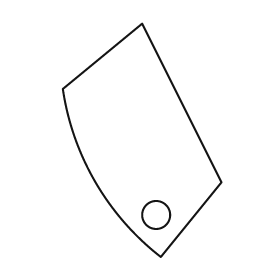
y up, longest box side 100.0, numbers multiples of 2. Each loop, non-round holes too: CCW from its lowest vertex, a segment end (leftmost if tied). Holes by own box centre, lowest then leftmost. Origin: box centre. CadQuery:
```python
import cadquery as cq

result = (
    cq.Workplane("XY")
    .moveTo(8.0, -50.0)
    .lineTo(34.0, -18.0)
    .lineTo(0.0, 50.0)
    .lineTo(-34.0, 22.0)
    .threePointArc((-20.0, -18.0), (8.0, -50.0))
    .close()
    .moveTo(6.0, -32.0)
    .circle(6.0)
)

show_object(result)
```